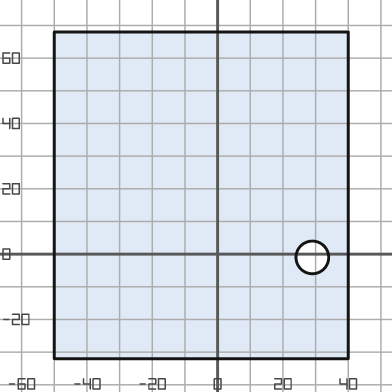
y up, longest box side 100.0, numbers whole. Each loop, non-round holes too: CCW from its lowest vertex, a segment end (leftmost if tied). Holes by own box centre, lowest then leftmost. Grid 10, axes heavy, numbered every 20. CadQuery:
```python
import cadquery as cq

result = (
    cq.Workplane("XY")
    .moveTo(-50.0, -32.0)
    .lineTo(40.0, -32.0)
    .lineTo(40.0, 68.0)
    .lineTo(-50.0, 68.0)
    .close()
    .moveTo(29.0, -1.0)
    .circle(5.0)
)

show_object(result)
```